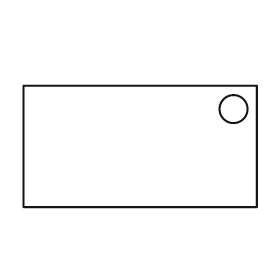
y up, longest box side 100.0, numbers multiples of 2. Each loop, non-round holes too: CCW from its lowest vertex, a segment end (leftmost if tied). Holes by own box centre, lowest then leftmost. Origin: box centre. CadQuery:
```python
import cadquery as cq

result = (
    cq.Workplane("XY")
    .moveTo(-50.0, -26.0)
    .lineTo(50.0, -26.0)
    .lineTo(50.0, 26.0)
    .lineTo(-50.0, 26.0)
    .close()
    .moveTo(40.0, 16.0)
    .circle(6.0)
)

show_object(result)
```